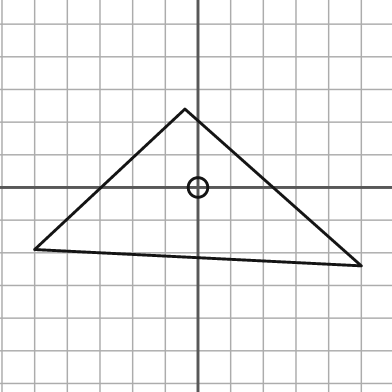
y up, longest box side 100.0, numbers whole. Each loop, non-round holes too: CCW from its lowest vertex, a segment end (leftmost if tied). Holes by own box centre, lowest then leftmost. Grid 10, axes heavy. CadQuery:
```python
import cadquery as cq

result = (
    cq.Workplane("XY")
    .moveTo(50.0, -24.0)
    .lineTo(-4.0, 24.0)
    .lineTo(-50.0, -19.0)
    .close()
    .moveTo(0.0, 0.0)
    .circle(3.0)
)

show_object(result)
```